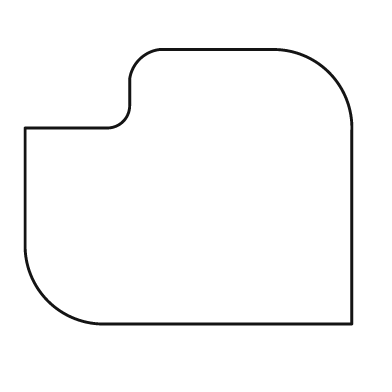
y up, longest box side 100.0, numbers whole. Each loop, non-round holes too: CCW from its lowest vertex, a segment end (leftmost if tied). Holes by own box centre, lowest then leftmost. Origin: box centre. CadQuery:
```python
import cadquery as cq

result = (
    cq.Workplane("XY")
    .moveTo(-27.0, -42.0)
    .lineTo(50.0, -42.0)
    .lineTo(50.0, 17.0)
    .threePointArc((43.0, 35.0), (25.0, 42.0))
    .lineTo(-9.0, 42.0)
    .threePointArc((-15.0, 39.0), (-18.0, 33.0))
    .lineTo(-18.0, 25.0)
    .threePointArc((-20.0, 20.0), (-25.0, 18.0))
    .lineTo(-50.0, 18.0)
    .lineTo(-50.0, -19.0)
    .threePointArc((-43.0, -35.0), (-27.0, -42.0))
    .close()
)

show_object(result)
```